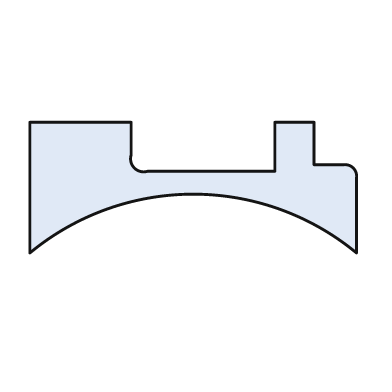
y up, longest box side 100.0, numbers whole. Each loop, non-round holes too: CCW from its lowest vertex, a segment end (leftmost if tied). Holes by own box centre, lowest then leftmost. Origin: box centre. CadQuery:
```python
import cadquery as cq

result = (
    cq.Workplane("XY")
    .moveTo(-50.0, -20.0)
    .threePointArc((0.0, -2.0), (50.0, -20.0))
    .lineTo(50.0, 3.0)
    .threePointArc((49.0, 6.0), (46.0, 7.0))
    .lineTo(37.0, 7.0)
    .lineTo(37.0, 20.0)
    .lineTo(25.0, 20.0)
    .lineTo(25.0, 5.0)
    .lineTo(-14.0, 5.0)
    .threePointArc((-18.0, 6.0), (-19.0, 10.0))
    .lineTo(-19.0, 20.0)
    .lineTo(-50.0, 20.0)
    .close()
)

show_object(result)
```